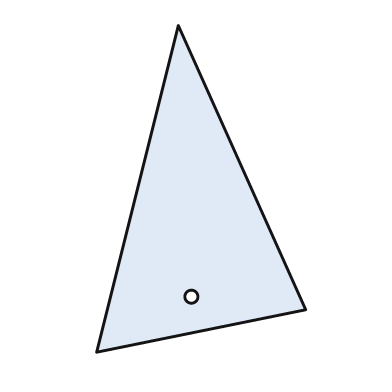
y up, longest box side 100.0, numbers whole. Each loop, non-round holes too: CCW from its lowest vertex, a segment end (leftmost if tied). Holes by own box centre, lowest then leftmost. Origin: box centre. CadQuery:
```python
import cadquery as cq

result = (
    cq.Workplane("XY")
    .moveTo(-32.0, -50.0)
    .lineTo(32.0, -37.0)
    .lineTo(-7.0, 50.0)
    .close()
    .moveTo(-3.0, -33.0)
    .circle(2.0)
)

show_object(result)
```